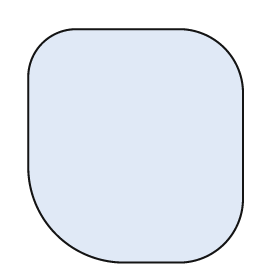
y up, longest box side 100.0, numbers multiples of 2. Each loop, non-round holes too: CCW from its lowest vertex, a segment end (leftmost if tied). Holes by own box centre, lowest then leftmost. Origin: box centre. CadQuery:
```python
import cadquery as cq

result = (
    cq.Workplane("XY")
    .moveTo(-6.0, -50.0)
    .lineTo(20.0, -50.0)
    .threePointArc((38.0, -42.0), (46.0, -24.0))
    .lineTo(46.0, 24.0)
    .threePointArc((38.0, 42.0), (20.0, 50.0))
    .lineTo(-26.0, 50.0)
    .threePointArc((-40.0, 44.0), (-46.0, 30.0))
    .lineTo(-46.0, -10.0)
    .threePointArc((-34.0, -38.0), (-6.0, -50.0))
    .close()
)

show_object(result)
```